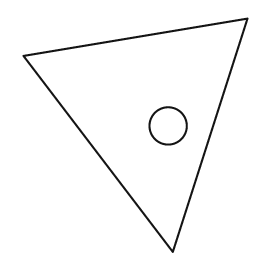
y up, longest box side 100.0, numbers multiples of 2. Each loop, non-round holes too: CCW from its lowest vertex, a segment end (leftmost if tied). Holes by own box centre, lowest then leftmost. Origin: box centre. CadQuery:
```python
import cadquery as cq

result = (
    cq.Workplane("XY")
    .moveTo(16.0, -50.0)
    .lineTo(48.0, 50.0)
    .lineTo(-48.0, 34.0)
    .close()
    .moveTo(14.0, 4.0)
    .circle(8.0)
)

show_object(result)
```